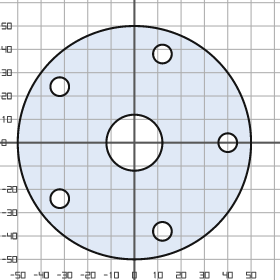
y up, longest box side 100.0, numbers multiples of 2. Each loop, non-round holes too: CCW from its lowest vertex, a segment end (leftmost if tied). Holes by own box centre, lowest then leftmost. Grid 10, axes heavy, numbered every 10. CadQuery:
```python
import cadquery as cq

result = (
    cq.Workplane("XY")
    .moveTo(0.0, 0.0)
    .circle(50.0)
    .moveTo(12.0, -38.0)
    .circle(4.0)
    .moveTo(-32.0, -24.0)
    .circle(4.0)
    .moveTo(0.0, 0.0)
    .circle(12.0)
    .moveTo(40.0, 0.0)
    .circle(4.0)
    .moveTo(-32.0, 24.0)
    .circle(4.0)
    .moveTo(12.0, 38.0)
    .circle(4.0)
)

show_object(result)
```